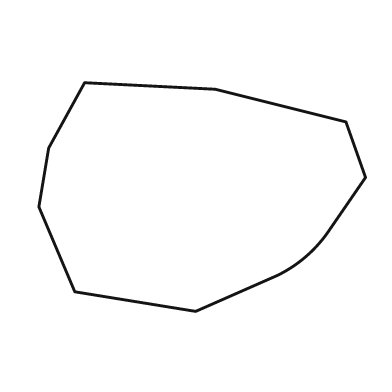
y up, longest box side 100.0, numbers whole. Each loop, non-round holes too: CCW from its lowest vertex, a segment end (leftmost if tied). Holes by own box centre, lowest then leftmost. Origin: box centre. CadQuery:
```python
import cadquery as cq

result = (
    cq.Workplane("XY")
    .moveTo(-2.0, -35.0)
    .lineTo(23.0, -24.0)
    .threePointArc((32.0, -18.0), (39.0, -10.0))
    .lineTo(50.0, 6.0)
    .lineTo(44.0, 23.0)
    .lineTo(4.0, 33.0)
    .lineTo(-36.0, 35.0)
    .lineTo(-47.0, 15.0)
    .lineTo(-50.0, -3.0)
    .lineTo(-39.0, -29.0)
    .close()
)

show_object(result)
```